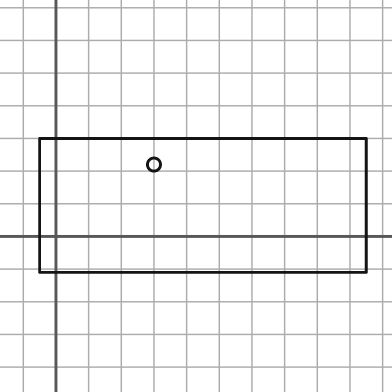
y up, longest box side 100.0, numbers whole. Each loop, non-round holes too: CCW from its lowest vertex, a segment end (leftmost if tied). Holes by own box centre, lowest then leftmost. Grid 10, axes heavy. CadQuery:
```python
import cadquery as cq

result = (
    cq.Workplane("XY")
    .moveTo(-5.0, -11.0)
    .lineTo(95.0, -11.0)
    .lineTo(95.0, 30.0)
    .lineTo(-5.0, 30.0)
    .close()
    .moveTo(30.0, 22.0)
    .circle(2.0)
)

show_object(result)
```